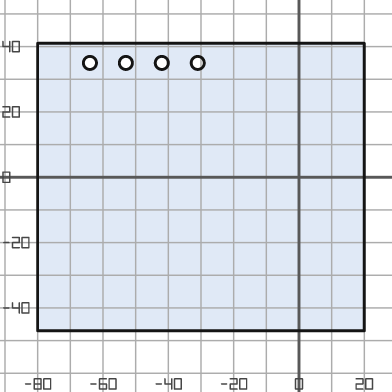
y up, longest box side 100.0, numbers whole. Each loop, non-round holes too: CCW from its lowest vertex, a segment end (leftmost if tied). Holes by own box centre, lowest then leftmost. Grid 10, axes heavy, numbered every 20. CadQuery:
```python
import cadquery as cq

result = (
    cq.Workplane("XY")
    .moveTo(-80.0, -47.0)
    .lineTo(20.0, -47.0)
    .lineTo(20.0, 41.0)
    .lineTo(-80.0, 41.0)
    .close()
    .moveTo(-64.0, 35.0)
    .circle(2.0)
    .moveTo(-53.0, 35.0)
    .circle(2.0)
    .moveTo(-42.0, 35.0)
    .circle(2.0)
    .moveTo(-31.0, 35.0)
    .circle(2.0)
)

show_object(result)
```